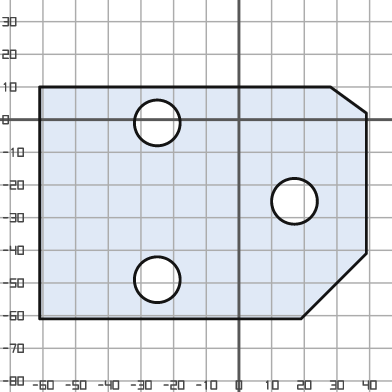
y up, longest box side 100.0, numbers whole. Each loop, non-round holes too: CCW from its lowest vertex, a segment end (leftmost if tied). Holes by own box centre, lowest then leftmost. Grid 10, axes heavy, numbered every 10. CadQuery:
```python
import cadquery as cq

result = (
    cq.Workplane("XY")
    .moveTo(-61.0, -61.0)
    .lineTo(19.0, -61.0)
    .lineTo(39.0, -41.0)
    .lineTo(39.0, 2.0)
    .lineTo(28.0, 10.0)
    .lineTo(-61.0, 10.0)
    .close()
    .moveTo(-25.0, -49.0)
    .circle(7.0)
    .moveTo(17.0, -25.0)
    .circle(7.0)
    .moveTo(-25.0, -1.0)
    .circle(7.0)
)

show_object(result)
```